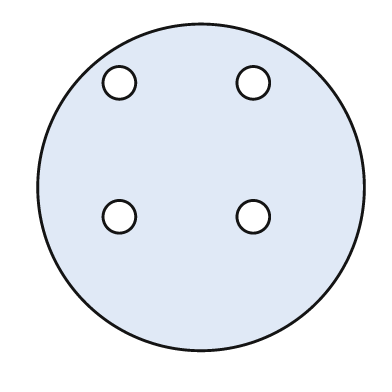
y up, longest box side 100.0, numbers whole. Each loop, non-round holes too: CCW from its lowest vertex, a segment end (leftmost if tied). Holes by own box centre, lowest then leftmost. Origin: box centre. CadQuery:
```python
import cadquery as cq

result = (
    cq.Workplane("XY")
    .moveTo(0.0, 0.0)
    .circle(50.0)
    .moveTo(-25.0, -9.0)
    .circle(5.0)
    .moveTo(16.0, -9.0)
    .circle(5.0)
    .moveTo(-25.0, 32.0)
    .circle(5.0)
    .moveTo(16.0, 32.0)
    .circle(5.0)
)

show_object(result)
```